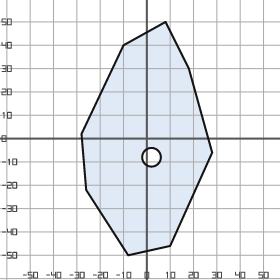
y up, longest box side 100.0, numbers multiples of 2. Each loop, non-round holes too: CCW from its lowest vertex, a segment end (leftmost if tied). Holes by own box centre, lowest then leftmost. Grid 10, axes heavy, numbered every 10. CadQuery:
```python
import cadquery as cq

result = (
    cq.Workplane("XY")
    .moveTo(-8.0, -50.0)
    .lineTo(10.0, -46.0)
    .lineTo(28.0, -6.0)
    .lineTo(18.0, 30.0)
    .lineTo(8.0, 50.0)
    .lineTo(-10.0, 40.0)
    .lineTo(-28.0, 2.0)
    .lineTo(-26.0, -22.0)
    .close()
    .moveTo(2.0, -8.0)
    .circle(4.0)
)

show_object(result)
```